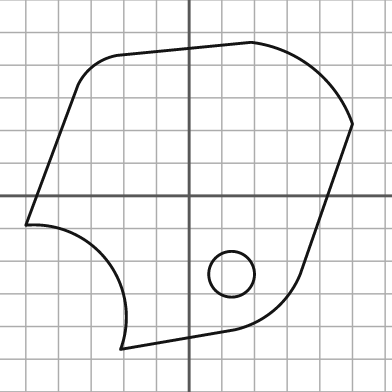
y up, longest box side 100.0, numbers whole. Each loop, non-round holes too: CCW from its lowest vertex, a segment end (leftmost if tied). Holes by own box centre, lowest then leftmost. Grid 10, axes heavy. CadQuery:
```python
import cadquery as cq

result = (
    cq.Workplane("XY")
    .moveTo(-21.0, -47.0)
    .lineTo(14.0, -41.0)
    .threePointArc((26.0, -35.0), (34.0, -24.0))
    .lineTo(50.0, 22.0)
    .threePointArc((38.0, 39.0), (19.0, 47.0))
    .lineTo(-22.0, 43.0)
    .threePointArc((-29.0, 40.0), (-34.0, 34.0))
    .lineTo(-50.0, -9.0)
    .threePointArc((-25.0, -20.0), (-21.0, -47.0))
    .close()
    .moveTo(13.0, -24.0)
    .circle(7.0)
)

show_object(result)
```